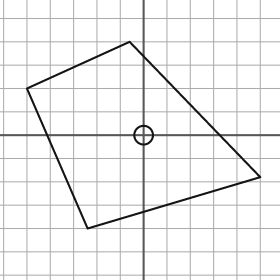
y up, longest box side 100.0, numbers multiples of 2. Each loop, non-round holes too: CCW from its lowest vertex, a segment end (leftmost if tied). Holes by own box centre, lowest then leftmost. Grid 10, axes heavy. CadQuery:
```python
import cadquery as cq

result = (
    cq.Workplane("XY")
    .moveTo(-24.0, -40.0)
    .lineTo(50.0, -18.0)
    .lineTo(-6.0, 40.0)
    .lineTo(-50.0, 20.0)
    .close()
    .moveTo(0.0, 0.0)
    .circle(4.0)
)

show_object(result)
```